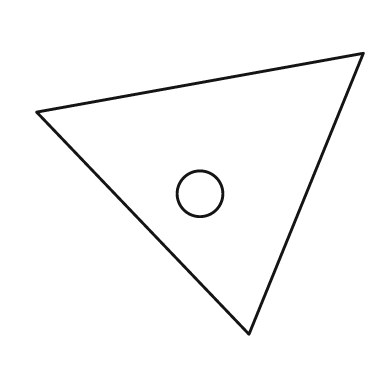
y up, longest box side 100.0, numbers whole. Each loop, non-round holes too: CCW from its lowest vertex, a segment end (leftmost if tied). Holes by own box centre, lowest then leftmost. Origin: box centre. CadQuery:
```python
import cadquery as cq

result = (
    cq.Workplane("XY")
    .moveTo(15.0, -43.0)
    .lineTo(50.0, 43.0)
    .lineTo(-50.0, 25.0)
    .close()
    .moveTo(0.0, 0.0)
    .circle(7.0)
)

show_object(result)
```